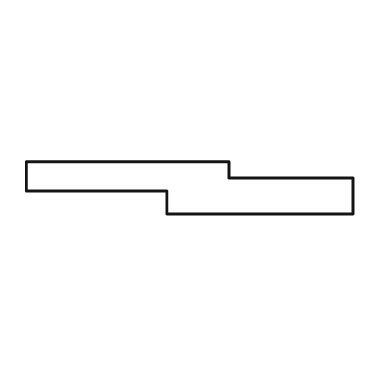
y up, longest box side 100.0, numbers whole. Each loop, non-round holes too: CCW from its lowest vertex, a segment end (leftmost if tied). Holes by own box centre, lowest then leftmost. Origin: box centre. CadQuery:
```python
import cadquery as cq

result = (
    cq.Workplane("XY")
    .moveTo(-7.0, -8.0)
    .lineTo(50.0, -8.0)
    .lineTo(50.0, 3.0)
    .lineTo(12.0, 3.0)
    .lineTo(12.0, 8.0)
    .lineTo(-50.0, 8.0)
    .lineTo(-50.0, -1.0)
    .lineTo(-7.0, -1.0)
    .close()
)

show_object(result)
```